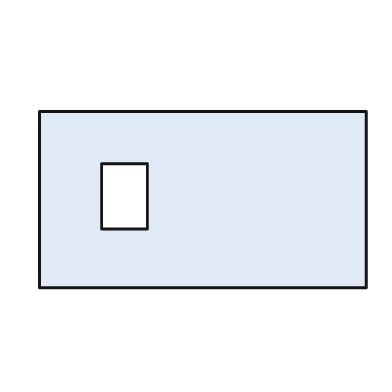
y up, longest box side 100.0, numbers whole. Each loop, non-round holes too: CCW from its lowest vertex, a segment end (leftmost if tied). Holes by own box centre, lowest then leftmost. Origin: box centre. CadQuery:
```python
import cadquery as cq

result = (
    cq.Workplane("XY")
    .moveTo(-50.0, -27.0)
    .lineTo(50.0, -27.0)
    .lineTo(50.0, 27.0)
    .lineTo(-50.0, 27.0)
    .close()
    .moveTo(-31.0, -9.0)
    .lineTo(-17.0, -9.0)
    .lineTo(-17.0, 11.0)
    .lineTo(-31.0, 11.0)
    .close()
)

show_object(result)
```